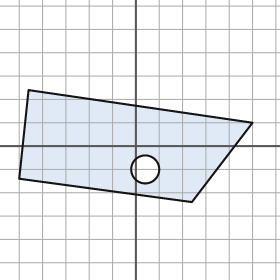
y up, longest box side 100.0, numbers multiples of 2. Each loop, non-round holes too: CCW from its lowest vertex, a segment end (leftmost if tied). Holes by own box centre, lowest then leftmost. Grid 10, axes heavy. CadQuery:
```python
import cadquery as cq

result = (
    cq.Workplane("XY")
    .moveTo(24.0, -24.0)
    .lineTo(50.0, 10.0)
    .lineTo(-46.0, 24.0)
    .lineTo(-50.0, -14.0)
    .close()
    .moveTo(4.0, -10.0)
    .circle(6.0)
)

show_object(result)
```